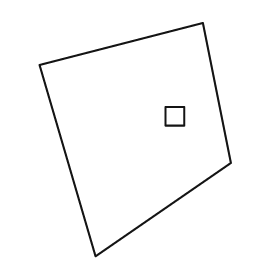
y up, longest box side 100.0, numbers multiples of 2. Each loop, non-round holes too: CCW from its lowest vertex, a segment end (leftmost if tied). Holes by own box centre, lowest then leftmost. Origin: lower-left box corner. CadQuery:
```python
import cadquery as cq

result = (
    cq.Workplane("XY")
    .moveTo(24.0, 0.0)
    .lineTo(82.0, 40.0)
    .lineTo(70.0, 100.0)
    .lineTo(0.0, 82.0)
    .close()
    .moveTo(54.0, 56.0)
    .lineTo(62.0, 56.0)
    .lineTo(62.0, 64.0)
    .lineTo(54.0, 64.0)
    .close()
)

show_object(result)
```